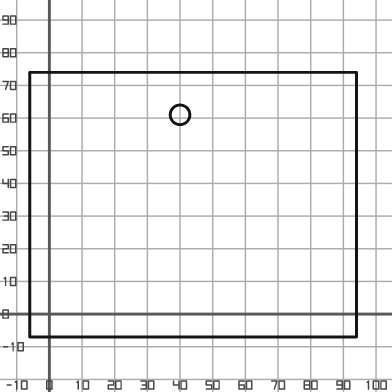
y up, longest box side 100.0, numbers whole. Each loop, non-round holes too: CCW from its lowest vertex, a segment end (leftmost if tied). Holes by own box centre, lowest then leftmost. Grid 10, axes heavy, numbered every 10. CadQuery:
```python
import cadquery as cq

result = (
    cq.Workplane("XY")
    .moveTo(-6.0, -7.0)
    .lineTo(94.0, -7.0)
    .lineTo(94.0, 74.0)
    .lineTo(-6.0, 74.0)
    .close()
    .moveTo(40.0, 61.0)
    .circle(3.0)
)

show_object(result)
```